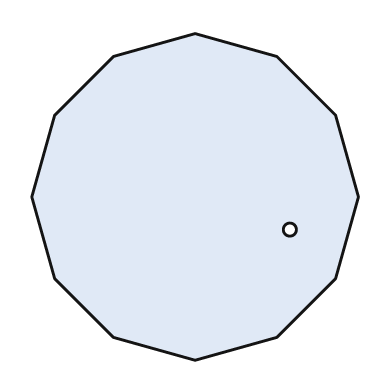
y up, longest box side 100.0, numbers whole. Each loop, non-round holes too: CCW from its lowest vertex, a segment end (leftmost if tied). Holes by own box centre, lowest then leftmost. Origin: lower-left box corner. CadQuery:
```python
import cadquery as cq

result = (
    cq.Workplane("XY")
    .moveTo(50.0, 0.0)
    .lineTo(75.0, 7.0)
    .lineTo(93.0, 25.0)
    .lineTo(100.0, 50.0)
    .lineTo(93.0, 75.0)
    .lineTo(75.0, 93.0)
    .lineTo(50.0, 100.0)
    .lineTo(25.0, 93.0)
    .lineTo(7.0, 75.0)
    .lineTo(0.0, 50.0)
    .lineTo(7.0, 25.0)
    .lineTo(25.0, 7.0)
    .close()
    .moveTo(79.0, 40.0)
    .circle(2.0)
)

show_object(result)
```